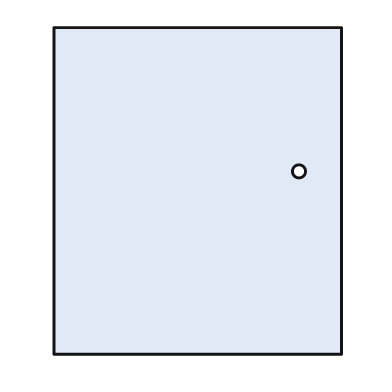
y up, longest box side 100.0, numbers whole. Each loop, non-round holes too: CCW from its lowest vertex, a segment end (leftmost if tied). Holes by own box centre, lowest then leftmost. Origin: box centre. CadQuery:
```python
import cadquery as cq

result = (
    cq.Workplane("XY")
    .moveTo(-44.0, -50.0)
    .lineTo(44.0, -50.0)
    .lineTo(44.0, 50.0)
    .lineTo(-44.0, 50.0)
    .close()
    .moveTo(31.0, 6.0)
    .circle(2.0)
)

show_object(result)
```